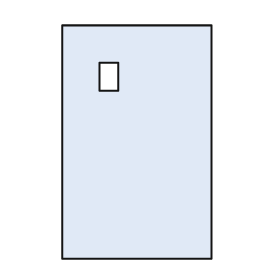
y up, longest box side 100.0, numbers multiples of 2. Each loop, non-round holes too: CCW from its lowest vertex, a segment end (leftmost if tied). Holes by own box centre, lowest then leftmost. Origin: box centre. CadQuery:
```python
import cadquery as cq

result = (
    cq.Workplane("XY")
    .moveTo(-32.0, -50.0)
    .lineTo(32.0, -50.0)
    .lineTo(32.0, 50.0)
    .lineTo(-32.0, 50.0)
    .close()
    .moveTo(-16.0, 22.0)
    .lineTo(-8.0, 22.0)
    .lineTo(-8.0, 34.0)
    .lineTo(-16.0, 34.0)
    .close()
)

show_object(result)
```